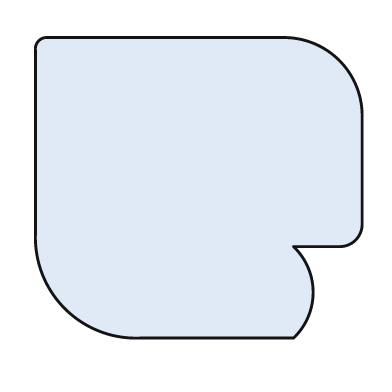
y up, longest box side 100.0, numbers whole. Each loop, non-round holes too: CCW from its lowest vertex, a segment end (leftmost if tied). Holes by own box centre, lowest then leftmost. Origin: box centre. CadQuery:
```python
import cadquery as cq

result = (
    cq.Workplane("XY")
    .moveTo(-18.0, -46.0)
    .lineTo(29.0, -46.0)
    .threePointArc((35.0, -32.0), (29.0, -18.0))
    .lineTo(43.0, -18.0)
    .threePointArc((48.0, -16.0), (50.0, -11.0))
    .lineTo(50.0, 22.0)
    .threePointArc((43.0, 39.0), (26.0, 46.0))
    .lineTo(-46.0, 46.0)
    .threePointArc((-49.0, 45.0), (-50.0, 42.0))
    .lineTo(-50.0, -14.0)
    .threePointArc((-41.0, -37.0), (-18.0, -46.0))
    .close()
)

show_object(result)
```